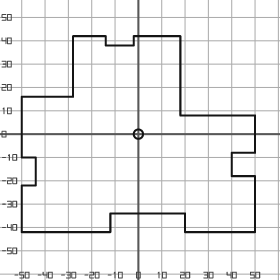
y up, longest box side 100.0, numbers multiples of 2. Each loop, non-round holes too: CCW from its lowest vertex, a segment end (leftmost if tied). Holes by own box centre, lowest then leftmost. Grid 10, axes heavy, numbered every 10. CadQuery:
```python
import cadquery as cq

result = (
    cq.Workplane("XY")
    .moveTo(-50.0, -42.0)
    .lineTo(-12.0, -42.0)
    .lineTo(-12.0, -34.0)
    .lineTo(20.0, -34.0)
    .lineTo(20.0, -42.0)
    .lineTo(50.0, -42.0)
    .lineTo(50.0, -18.0)
    .lineTo(40.0, -18.0)
    .lineTo(40.0, -8.0)
    .lineTo(50.0, -8.0)
    .lineTo(50.0, 8.0)
    .lineTo(18.0, 8.0)
    .lineTo(18.0, 42.0)
    .lineTo(-2.0, 42.0)
    .lineTo(-2.0, 38.0)
    .lineTo(-14.0, 38.0)
    .lineTo(-14.0, 42.0)
    .lineTo(-28.0, 42.0)
    .lineTo(-28.0, 16.0)
    .lineTo(-50.0, 16.0)
    .lineTo(-50.0, -10.0)
    .lineTo(-44.0, -10.0)
    .lineTo(-44.0, -22.0)
    .lineTo(-50.0, -22.0)
    .close()
    .moveTo(0.0, 0.0)
    .circle(2.0)
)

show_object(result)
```